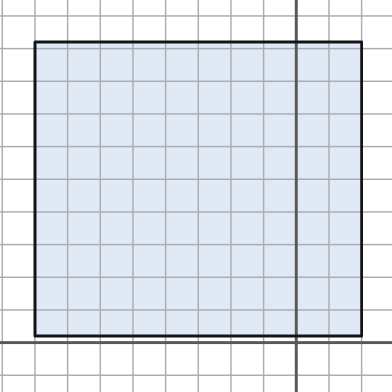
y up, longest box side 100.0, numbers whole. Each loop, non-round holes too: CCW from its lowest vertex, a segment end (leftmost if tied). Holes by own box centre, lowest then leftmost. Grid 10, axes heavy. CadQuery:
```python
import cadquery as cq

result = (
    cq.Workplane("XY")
    .moveTo(-80.0, 2.0)
    .lineTo(20.0, 2.0)
    .lineTo(20.0, 92.0)
    .lineTo(-80.0, 92.0)
    .close()
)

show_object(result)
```